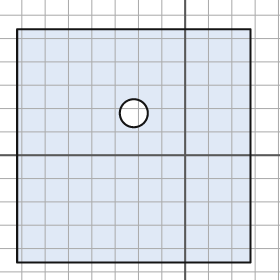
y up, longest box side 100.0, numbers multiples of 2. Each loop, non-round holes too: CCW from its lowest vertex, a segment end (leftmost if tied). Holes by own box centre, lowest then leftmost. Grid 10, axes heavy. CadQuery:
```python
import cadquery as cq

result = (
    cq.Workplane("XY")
    .moveTo(-72.0, -46.0)
    .lineTo(28.0, -46.0)
    .lineTo(28.0, 54.0)
    .lineTo(-72.0, 54.0)
    .close()
    .moveTo(-22.0, 18.0)
    .circle(6.0)
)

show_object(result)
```